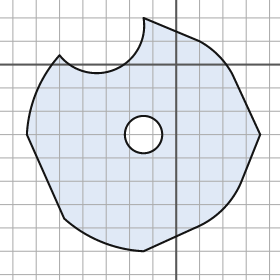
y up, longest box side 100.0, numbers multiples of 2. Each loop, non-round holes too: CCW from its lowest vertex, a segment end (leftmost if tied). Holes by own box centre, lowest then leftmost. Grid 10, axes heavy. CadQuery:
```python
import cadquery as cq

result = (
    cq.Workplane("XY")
    .moveTo(-14.0, -80.0)
    .lineTo(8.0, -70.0)
    .threePointArc((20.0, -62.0), (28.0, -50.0))
    .lineTo(36.0, -30.0)
    .lineTo(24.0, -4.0)
    .threePointArc((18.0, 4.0), (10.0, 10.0))
    .lineTo(-14.0, 20.0)
    .threePointArc((-26.0, -2.0), (-50.0, 4.0))
    .threePointArc((-60.0, -12.0), (-64.0, -30.0))
    .lineTo(-48.0, -66.0)
    .threePointArc((-32.0, -76.0), (-14.0, -80.0))
    .close()
    .moveTo(-14.0, -30.0)
    .circle(8.0)
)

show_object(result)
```